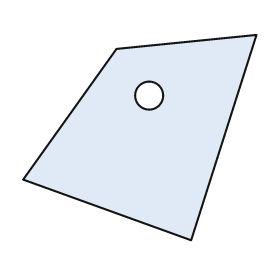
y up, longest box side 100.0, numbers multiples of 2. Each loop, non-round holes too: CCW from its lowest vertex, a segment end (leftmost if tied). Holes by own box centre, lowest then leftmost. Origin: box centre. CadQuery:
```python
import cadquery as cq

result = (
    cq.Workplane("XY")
    .moveTo(22.0, -44.0)
    .lineTo(50.0, 44.0)
    .lineTo(-10.0, 38.0)
    .lineTo(-50.0, -18.0)
    .close()
    .moveTo(4.0, 18.0)
    .circle(6.0)
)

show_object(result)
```